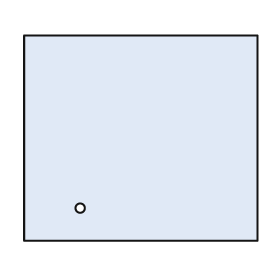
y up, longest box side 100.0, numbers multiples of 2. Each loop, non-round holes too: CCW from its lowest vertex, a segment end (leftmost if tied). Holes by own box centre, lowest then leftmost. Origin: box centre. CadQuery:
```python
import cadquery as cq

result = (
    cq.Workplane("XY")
    .moveTo(-50.0, -44.0)
    .lineTo(50.0, -44.0)
    .lineTo(50.0, 44.0)
    .lineTo(-50.0, 44.0)
    .close()
    .moveTo(-26.0, -30.0)
    .circle(2.0)
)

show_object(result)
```